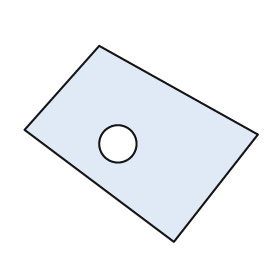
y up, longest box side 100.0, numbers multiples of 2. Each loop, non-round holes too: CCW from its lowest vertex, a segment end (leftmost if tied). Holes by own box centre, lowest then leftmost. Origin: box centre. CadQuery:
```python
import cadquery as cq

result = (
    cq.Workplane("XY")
    .moveTo(14.0, -42.0)
    .lineTo(50.0, 4.0)
    .lineTo(-18.0, 42.0)
    .lineTo(-50.0, 6.0)
    .close()
    .moveTo(-10.0, 0.0)
    .circle(8.0)
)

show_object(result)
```